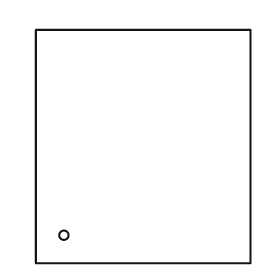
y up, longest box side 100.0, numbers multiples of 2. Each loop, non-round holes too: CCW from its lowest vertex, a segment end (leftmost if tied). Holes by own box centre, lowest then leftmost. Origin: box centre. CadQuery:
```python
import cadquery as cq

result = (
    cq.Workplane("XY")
    .moveTo(-46.0, -50.0)
    .lineTo(46.0, -50.0)
    .lineTo(46.0, 50.0)
    .lineTo(-46.0, 50.0)
    .close()
    .moveTo(-34.0, -38.0)
    .circle(2.0)
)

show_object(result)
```